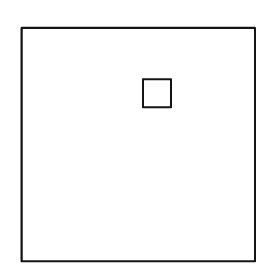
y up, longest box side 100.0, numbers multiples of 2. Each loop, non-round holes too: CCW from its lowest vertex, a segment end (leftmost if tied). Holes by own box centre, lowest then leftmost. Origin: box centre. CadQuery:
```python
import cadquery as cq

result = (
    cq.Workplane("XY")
    .moveTo(-50.0, -50.0)
    .lineTo(50.0, -50.0)
    .lineTo(50.0, 50.0)
    .lineTo(-50.0, 50.0)
    .close()
    .moveTo(2.0, 16.0)
    .lineTo(14.0, 16.0)
    .lineTo(14.0, 28.0)
    .lineTo(2.0, 28.0)
    .close()
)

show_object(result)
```